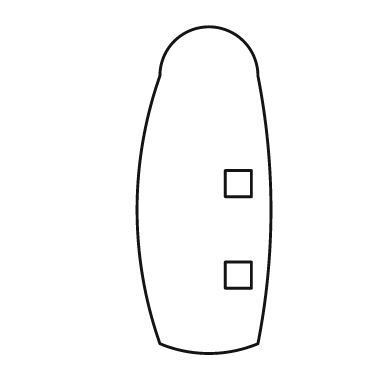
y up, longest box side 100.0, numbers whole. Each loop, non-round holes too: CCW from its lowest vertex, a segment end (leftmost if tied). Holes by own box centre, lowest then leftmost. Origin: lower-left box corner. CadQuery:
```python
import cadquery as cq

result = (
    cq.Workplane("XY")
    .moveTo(7.0, 3.0)
    .threePointArc((22.0, 0.0), (37.0, 3.0))
    .threePointArc((41.0, 44.0), (37.0, 85.0))
    .threePointArc((22.0, 100.0), (7.0, 85.0))
    .threePointArc((0.0, 44.0), (7.0, 3.0))
    .close()
    .moveTo(27.0, 20.0)
    .lineTo(35.0, 20.0)
    .lineTo(35.0, 28.0)
    .lineTo(27.0, 28.0)
    .close()
    .moveTo(27.0, 48.0)
    .lineTo(35.0, 48.0)
    .lineTo(35.0, 56.0)
    .lineTo(27.0, 56.0)
    .close()
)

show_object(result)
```